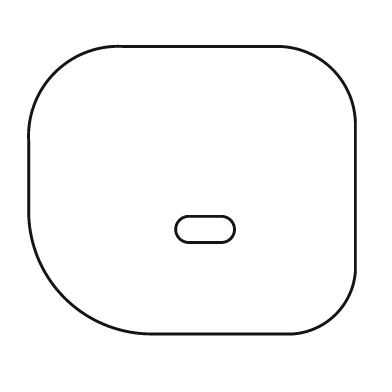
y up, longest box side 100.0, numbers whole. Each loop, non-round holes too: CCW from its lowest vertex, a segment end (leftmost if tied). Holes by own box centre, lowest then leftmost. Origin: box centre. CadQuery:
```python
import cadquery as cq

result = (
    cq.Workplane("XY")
    .moveTo(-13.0, -44.0)
    .lineTo(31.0, -44.0)
    .threePointArc((44.0, -38.0), (50.0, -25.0))
    .lineTo(50.0, 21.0)
    .threePointArc((43.0, 37.0), (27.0, 44.0))
    .lineTo(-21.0, 44.0)
    .threePointArc((-42.0, 36.0), (-50.0, 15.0))
    .lineTo(-50.0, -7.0)
    .threePointArc((-39.0, -33.0), (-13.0, -44.0))
    .close()
    .moveTo(-1.0, -16.0)
    .lineTo(9.0, -16.0)
    .threePointArc((13.0, -12.0), (9.0, -8.0))
    .lineTo(-1.0, -8.0)
    .threePointArc((-5.0, -12.0), (-1.0, -16.0))
    .close()
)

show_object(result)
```